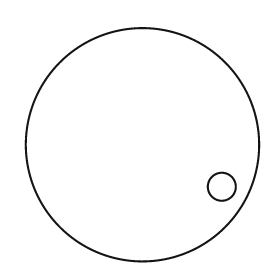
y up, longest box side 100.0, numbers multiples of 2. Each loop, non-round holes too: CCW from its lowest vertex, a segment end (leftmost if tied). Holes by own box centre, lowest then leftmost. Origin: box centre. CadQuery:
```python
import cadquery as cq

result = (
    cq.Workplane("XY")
    .moveTo(0.0, 0.0)
    .circle(50.0)
    .moveTo(34.0, -18.0)
    .circle(6.0)
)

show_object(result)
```